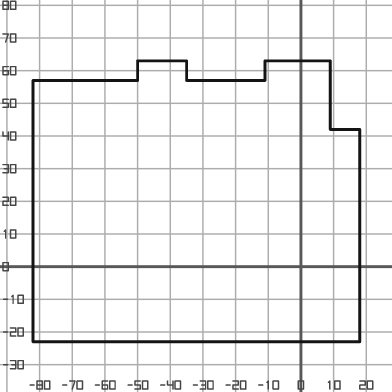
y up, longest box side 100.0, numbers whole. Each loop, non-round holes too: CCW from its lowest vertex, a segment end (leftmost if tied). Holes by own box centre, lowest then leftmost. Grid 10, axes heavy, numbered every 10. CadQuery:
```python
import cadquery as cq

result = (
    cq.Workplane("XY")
    .moveTo(-82.0, -23.0)
    .lineTo(18.0, -23.0)
    .lineTo(18.0, 42.0)
    .lineTo(9.0, 42.0)
    .lineTo(9.0, 63.0)
    .lineTo(-11.0, 63.0)
    .lineTo(-11.0, 57.0)
    .lineTo(-35.0, 57.0)
    .lineTo(-35.0, 63.0)
    .lineTo(-50.0, 63.0)
    .lineTo(-50.0, 57.0)
    .lineTo(-82.0, 57.0)
    .close()
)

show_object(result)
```